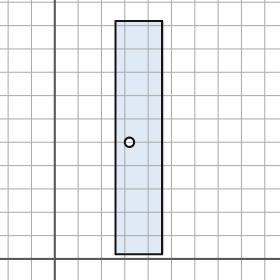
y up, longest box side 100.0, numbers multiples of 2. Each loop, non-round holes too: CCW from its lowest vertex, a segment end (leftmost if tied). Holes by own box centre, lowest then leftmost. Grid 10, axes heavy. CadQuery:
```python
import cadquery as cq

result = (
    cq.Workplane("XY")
    .moveTo(26.0, 2.0)
    .lineTo(46.0, 2.0)
    .lineTo(46.0, 102.0)
    .lineTo(26.0, 102.0)
    .close()
    .moveTo(32.0, 50.0)
    .circle(2.0)
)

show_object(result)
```